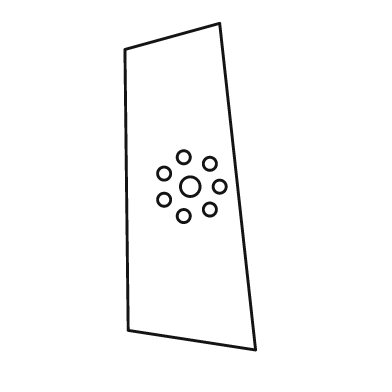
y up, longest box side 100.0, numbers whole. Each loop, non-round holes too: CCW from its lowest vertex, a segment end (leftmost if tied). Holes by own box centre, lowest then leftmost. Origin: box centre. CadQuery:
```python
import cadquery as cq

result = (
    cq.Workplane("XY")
    .moveTo(20.0, -50.0)
    .lineTo(9.0, 50.0)
    .lineTo(-20.0, 42.0)
    .lineTo(-19.0, -44.0)
    .close()
    .moveTo(-2.0, -9.0)
    .circle(2.0)
    .moveTo(6.0, -7.0)
    .circle(2.0)
    .moveTo(-8.0, -4.0)
    .circle(2.0)
    .moveTo(0.0, 0.0)
    .circle(3.0)
    .moveTo(9.0, 0.0)
    .circle(2.0)
    .moveTo(-8.0, 4.0)
    .circle(2.0)
    .moveTo(6.0, 7.0)
    .circle(2.0)
    .moveTo(-2.0, 9.0)
    .circle(2.0)
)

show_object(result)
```